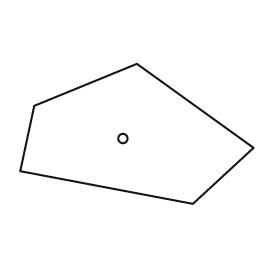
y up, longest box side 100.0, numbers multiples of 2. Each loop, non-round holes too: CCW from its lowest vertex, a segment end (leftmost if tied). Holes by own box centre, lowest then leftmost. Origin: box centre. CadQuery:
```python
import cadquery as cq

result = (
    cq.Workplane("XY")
    .moveTo(24.0, -30.0)
    .lineTo(50.0, -6.0)
    .lineTo(0.0, 30.0)
    .lineTo(-44.0, 12.0)
    .lineTo(-50.0, -16.0)
    .close()
    .moveTo(-6.0, -2.0)
    .circle(2.0)
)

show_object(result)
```